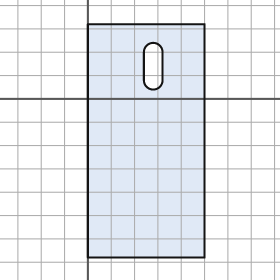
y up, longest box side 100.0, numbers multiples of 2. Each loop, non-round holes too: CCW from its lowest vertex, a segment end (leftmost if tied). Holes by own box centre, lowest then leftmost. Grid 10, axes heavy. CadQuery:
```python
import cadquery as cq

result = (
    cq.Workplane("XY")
    .moveTo(0.0, -68.0)
    .lineTo(50.0, -68.0)
    .lineTo(50.0, 32.0)
    .lineTo(0.0, 32.0)
    .close()
    .moveTo(24.0, 8.0)
    .threePointArc((28.0, 4.0), (32.0, 8.0))
    .lineTo(32.0, 20.0)
    .threePointArc((28.0, 24.0), (24.0, 20.0))
    .close()
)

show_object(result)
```